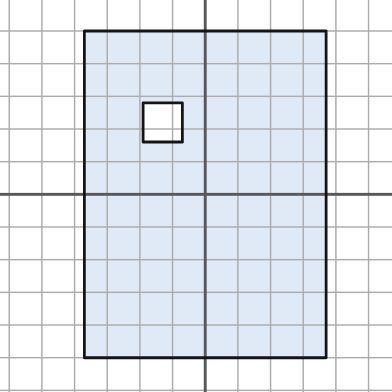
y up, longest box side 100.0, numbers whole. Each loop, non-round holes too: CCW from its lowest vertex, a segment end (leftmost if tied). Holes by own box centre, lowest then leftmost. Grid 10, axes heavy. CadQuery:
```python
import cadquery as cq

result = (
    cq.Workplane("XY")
    .moveTo(-37.0, -50.0)
    .lineTo(37.0, -50.0)
    .lineTo(37.0, 50.0)
    .lineTo(-37.0, 50.0)
    .close()
    .moveTo(-19.0, 16.0)
    .lineTo(-7.0, 16.0)
    .lineTo(-7.0, 28.0)
    .lineTo(-19.0, 28.0)
    .close()
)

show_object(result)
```